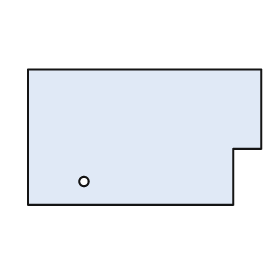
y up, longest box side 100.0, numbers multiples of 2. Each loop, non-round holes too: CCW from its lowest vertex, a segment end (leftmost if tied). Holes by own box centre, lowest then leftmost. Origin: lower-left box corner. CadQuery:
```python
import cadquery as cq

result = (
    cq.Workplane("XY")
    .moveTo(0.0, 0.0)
    .lineTo(88.0, 0.0)
    .lineTo(88.0, 24.0)
    .lineTo(100.0, 24.0)
    .lineTo(100.0, 58.0)
    .lineTo(0.0, 58.0)
    .close()
    .moveTo(24.0, 10.0)
    .circle(2.0)
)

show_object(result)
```